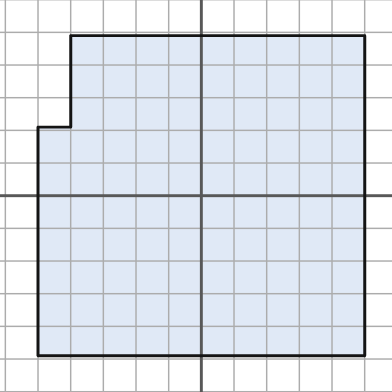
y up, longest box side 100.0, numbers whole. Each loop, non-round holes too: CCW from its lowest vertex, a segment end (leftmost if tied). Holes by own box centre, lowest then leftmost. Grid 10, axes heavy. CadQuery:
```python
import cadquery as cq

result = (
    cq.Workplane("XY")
    .moveTo(-50.0, -49.0)
    .lineTo(50.0, -49.0)
    .lineTo(50.0, 49.0)
    .lineTo(-40.0, 49.0)
    .lineTo(-40.0, 21.0)
    .lineTo(-50.0, 21.0)
    .close()
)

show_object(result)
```